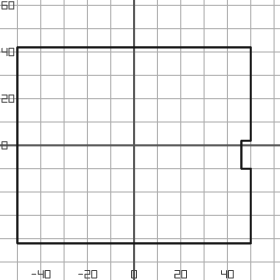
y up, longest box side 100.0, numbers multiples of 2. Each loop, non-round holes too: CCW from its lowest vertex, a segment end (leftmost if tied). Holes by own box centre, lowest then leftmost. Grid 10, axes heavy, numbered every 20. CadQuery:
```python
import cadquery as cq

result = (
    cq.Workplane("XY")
    .moveTo(-50.0, -42.0)
    .lineTo(50.0, -42.0)
    .lineTo(50.0, -10.0)
    .lineTo(46.0, -10.0)
    .lineTo(46.0, 2.0)
    .lineTo(50.0, 2.0)
    .lineTo(50.0, 42.0)
    .lineTo(-50.0, 42.0)
    .close()
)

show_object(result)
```